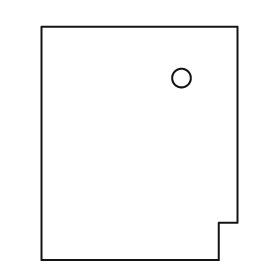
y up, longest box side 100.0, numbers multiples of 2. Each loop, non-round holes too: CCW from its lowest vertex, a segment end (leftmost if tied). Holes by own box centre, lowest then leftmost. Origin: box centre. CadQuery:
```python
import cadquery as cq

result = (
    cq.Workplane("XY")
    .moveTo(-42.0, -50.0)
    .lineTo(34.0, -50.0)
    .lineTo(34.0, -34.0)
    .lineTo(42.0, -34.0)
    .lineTo(42.0, 50.0)
    .lineTo(-42.0, 50.0)
    .close()
    .moveTo(18.0, 28.0)
    .circle(4.0)
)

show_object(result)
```